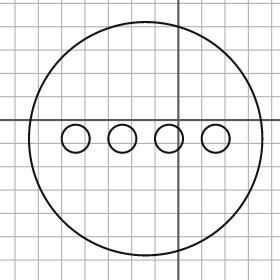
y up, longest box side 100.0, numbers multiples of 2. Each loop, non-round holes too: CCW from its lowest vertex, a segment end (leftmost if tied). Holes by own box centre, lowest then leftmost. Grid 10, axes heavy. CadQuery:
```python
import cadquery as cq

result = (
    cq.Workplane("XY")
    .moveTo(-14.0, -8.0)
    .circle(50.0)
    .moveTo(-44.0, -8.0)
    .circle(6.0)
    .moveTo(-24.0, -8.0)
    .circle(6.0)
    .moveTo(-4.0, -8.0)
    .circle(6.0)
    .moveTo(16.0, -8.0)
    .circle(6.0)
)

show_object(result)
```